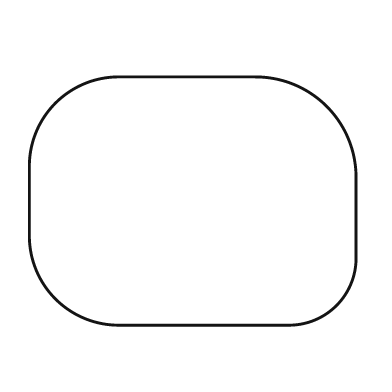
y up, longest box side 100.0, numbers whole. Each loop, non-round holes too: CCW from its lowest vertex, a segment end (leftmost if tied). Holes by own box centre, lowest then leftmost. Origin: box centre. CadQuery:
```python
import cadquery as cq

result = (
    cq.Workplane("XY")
    .moveTo(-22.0, -38.0)
    .lineTo(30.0, -38.0)
    .threePointArc((44.0, -32.0), (50.0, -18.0))
    .lineTo(50.0, 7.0)
    .threePointArc((41.0, 29.0), (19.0, 38.0))
    .lineTo(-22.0, 38.0)
    .threePointArc((-42.0, 30.0), (-50.0, 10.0))
    .lineTo(-50.0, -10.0)
    .threePointArc((-42.0, -30.0), (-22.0, -38.0))
    .close()
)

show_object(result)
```